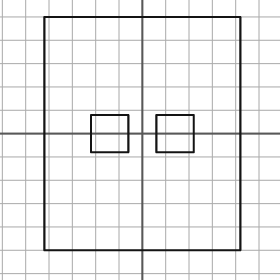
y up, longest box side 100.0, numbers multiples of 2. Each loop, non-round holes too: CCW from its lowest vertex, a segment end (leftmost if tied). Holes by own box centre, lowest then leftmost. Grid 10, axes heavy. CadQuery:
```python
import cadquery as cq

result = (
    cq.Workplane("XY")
    .moveTo(-42.0, -50.0)
    .lineTo(42.0, -50.0)
    .lineTo(42.0, 50.0)
    .lineTo(-42.0, 50.0)
    .close()
    .moveTo(-22.0, -8.0)
    .lineTo(-6.0, -8.0)
    .lineTo(-6.0, 8.0)
    .lineTo(-22.0, 8.0)
    .close()
    .moveTo(6.0, -8.0)
    .lineTo(22.0, -8.0)
    .lineTo(22.0, 8.0)
    .lineTo(6.0, 8.0)
    .close()
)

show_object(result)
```